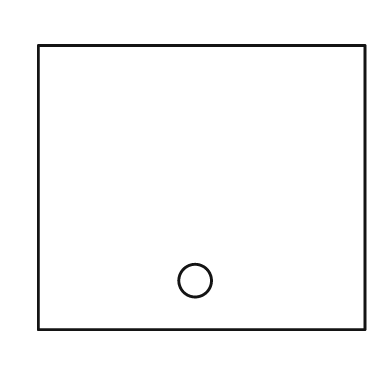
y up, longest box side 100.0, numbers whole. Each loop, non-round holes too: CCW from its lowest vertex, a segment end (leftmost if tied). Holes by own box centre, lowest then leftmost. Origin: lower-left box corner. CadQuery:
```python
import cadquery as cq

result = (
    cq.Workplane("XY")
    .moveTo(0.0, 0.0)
    .lineTo(100.0, 0.0)
    .lineTo(100.0, 87.0)
    .lineTo(0.0, 87.0)
    .close()
    .moveTo(48.0, 15.0)
    .circle(5.0)
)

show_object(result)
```